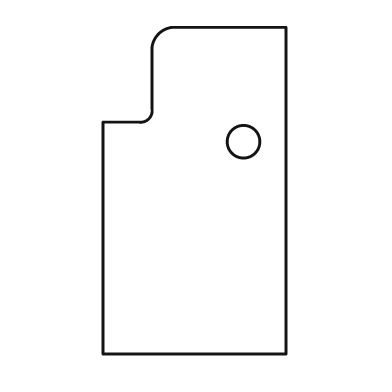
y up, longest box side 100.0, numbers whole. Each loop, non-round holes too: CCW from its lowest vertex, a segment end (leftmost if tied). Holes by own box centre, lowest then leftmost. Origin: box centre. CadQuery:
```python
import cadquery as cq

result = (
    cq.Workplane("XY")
    .moveTo(-28.0, -50.0)
    .lineTo(28.0, -50.0)
    .lineTo(28.0, 50.0)
    .lineTo(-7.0, 50.0)
    .threePointArc((-11.0, 48.0), (-13.0, 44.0))
    .lineTo(-13.0, 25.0)
    .threePointArc((-14.0, 22.0), (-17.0, 21.0))
    .lineTo(-28.0, 21.0)
    .close()
    .moveTo(15.0, 15.0)
    .circle(5.0)
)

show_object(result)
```